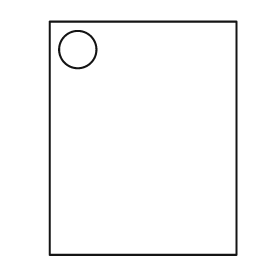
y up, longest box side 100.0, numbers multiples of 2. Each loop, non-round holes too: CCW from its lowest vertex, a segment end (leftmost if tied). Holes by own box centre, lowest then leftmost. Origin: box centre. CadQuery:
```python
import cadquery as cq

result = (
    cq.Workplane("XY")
    .moveTo(-40.0, -50.0)
    .lineTo(40.0, -50.0)
    .lineTo(40.0, 50.0)
    .lineTo(-40.0, 50.0)
    .close()
    .moveTo(-28.0, 38.0)
    .circle(8.0)
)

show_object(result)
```